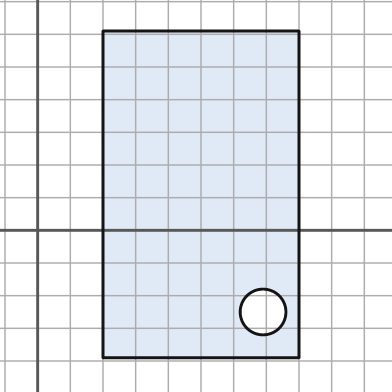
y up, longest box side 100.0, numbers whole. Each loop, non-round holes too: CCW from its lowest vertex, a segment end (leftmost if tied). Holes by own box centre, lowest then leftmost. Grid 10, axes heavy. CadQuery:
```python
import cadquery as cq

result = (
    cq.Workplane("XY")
    .moveTo(20.0, -39.0)
    .lineTo(80.0, -39.0)
    .lineTo(80.0, 61.0)
    .lineTo(20.0, 61.0)
    .close()
    .moveTo(69.0, -25.0)
    .circle(7.0)
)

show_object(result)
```